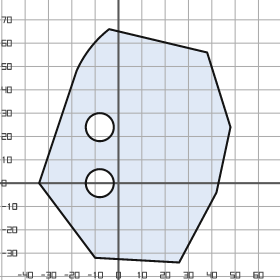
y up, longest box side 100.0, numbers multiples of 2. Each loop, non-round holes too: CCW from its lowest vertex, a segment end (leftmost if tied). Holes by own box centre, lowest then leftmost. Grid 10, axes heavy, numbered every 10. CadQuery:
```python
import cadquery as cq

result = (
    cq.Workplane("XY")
    .moveTo(26.0, -34.0)
    .lineTo(42.0, -4.0)
    .lineTo(48.0, 24.0)
    .lineTo(38.0, 56.0)
    .lineTo(-4.0, 66.0)
    .threePointArc((-12.0, 58.0), (-18.0, 48.0))
    .lineTo(-34.0, 0.0)
    .lineTo(-10.0, -32.0)
    .close()
    .moveTo(-8.0, 0.0)
    .circle(6.0)
    .moveTo(-8.0, 24.0)
    .circle(6.0)
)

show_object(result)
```